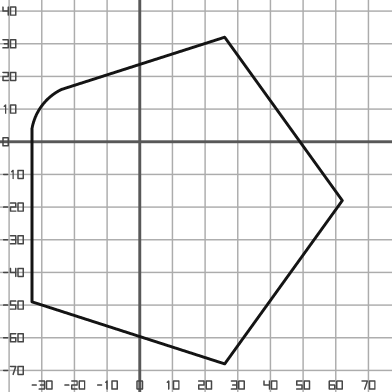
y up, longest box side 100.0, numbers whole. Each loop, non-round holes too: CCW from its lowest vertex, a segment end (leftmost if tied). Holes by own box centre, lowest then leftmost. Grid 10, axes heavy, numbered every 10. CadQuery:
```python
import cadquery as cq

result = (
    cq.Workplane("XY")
    .moveTo(26.0, -68.0)
    .lineTo(62.0, -18.0)
    .lineTo(26.0, 32.0)
    .lineTo(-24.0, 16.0)
    .threePointArc((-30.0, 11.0), (-33.0, 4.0))
    .lineTo(-33.0, -49.0)
    .close()
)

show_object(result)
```